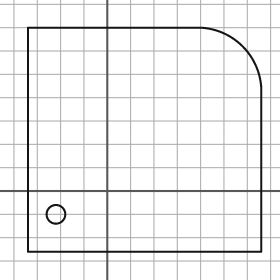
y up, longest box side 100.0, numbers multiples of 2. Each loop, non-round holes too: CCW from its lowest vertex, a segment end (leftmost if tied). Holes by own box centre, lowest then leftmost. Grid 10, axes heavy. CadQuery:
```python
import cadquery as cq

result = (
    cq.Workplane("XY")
    .moveTo(-34.0, -26.0)
    .lineTo(66.0, -26.0)
    .lineTo(66.0, 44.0)
    .threePointArc((58.0, 62.0), (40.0, 70.0))
    .lineTo(-34.0, 70.0)
    .close()
    .moveTo(-22.0, -10.0)
    .circle(4.0)
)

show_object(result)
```